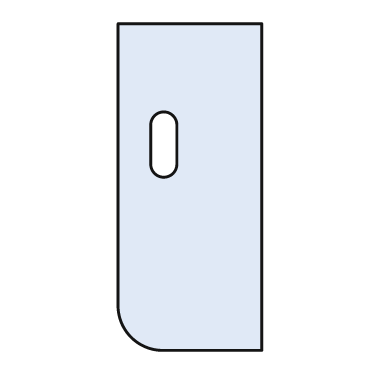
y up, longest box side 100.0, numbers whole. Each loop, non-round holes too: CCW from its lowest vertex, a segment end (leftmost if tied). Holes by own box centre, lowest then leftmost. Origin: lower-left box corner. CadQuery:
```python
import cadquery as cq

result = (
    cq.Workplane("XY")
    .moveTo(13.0, 0.0)
    .lineTo(44.0, 0.0)
    .lineTo(44.0, 100.0)
    .lineTo(0.0, 100.0)
    .lineTo(0.0, 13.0)
    .threePointArc((4.0, 4.0), (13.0, 0.0))
    .close()
    .moveTo(10.0, 57.0)
    .threePointArc((14.0, 53.0), (18.0, 57.0))
    .lineTo(18.0, 69.0)
    .threePointArc((14.0, 73.0), (10.0, 69.0))
    .close()
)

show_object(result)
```